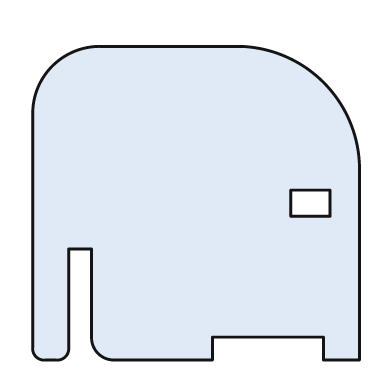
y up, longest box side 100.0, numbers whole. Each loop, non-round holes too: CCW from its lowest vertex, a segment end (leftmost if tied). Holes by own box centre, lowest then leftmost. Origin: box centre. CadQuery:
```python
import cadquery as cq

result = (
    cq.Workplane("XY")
    .moveTo(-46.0, -48.0)
    .lineTo(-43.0, -48.0)
    .threePointArc((-40.0, -47.0), (-39.0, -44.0))
    .lineTo(-39.0, -14.0)
    .lineTo(-32.0, -14.0)
    .lineTo(-32.0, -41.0)
    .threePointArc((-30.0, -46.0), (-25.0, -48.0))
    .lineTo(5.0, -48.0)
    .lineTo(5.0, -41.0)
    .lineTo(39.0, -41.0)
    .lineTo(39.0, -48.0)
    .lineTo(50.0, -48.0)
    .lineTo(50.0, 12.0)
    .threePointArc((39.0, 37.0), (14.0, 48.0))
    .lineTo(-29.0, 48.0)
    .threePointArc((-44.0, 42.0), (-50.0, 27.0))
    .lineTo(-50.0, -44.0)
    .threePointArc((-49.0, -47.0), (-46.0, -48.0))
    .close()
    .moveTo(29.0, -4.0)
    .lineTo(41.0, -4.0)
    .lineTo(41.0, 4.0)
    .lineTo(29.0, 4.0)
    .close()
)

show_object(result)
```